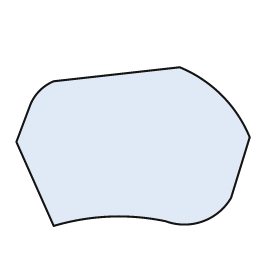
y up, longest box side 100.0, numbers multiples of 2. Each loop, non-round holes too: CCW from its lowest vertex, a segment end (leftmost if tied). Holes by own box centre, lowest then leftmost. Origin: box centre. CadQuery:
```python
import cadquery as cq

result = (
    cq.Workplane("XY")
    .moveTo(-34.0, -34.0)
    .threePointArc((-10.0, -30.0), (14.0, -32.0))
    .threePointArc((30.0, -32.0), (42.0, -22.0))
    .lineTo(50.0, 4.0)
    .threePointArc((38.0, 22.0), (20.0, 34.0))
    .lineTo(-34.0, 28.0)
    .threePointArc((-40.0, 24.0), (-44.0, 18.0))
    .lineTo(-50.0, 2.0)
    .close()
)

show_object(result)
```